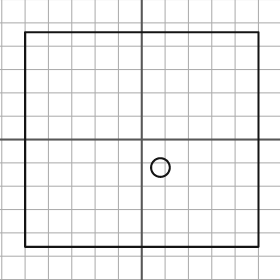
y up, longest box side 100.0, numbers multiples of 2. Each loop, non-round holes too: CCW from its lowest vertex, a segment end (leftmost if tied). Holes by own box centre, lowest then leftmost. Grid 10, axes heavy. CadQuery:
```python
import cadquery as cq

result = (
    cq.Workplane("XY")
    .moveTo(-50.0, -46.0)
    .lineTo(50.0, -46.0)
    .lineTo(50.0, 46.0)
    .lineTo(-50.0, 46.0)
    .close()
    .moveTo(8.0, -12.0)
    .circle(4.0)
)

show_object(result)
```